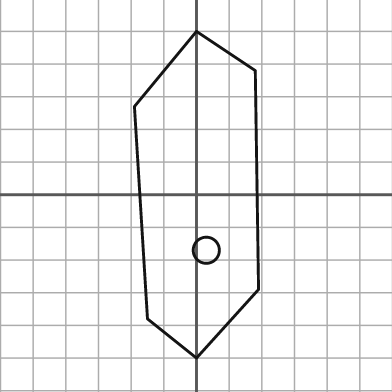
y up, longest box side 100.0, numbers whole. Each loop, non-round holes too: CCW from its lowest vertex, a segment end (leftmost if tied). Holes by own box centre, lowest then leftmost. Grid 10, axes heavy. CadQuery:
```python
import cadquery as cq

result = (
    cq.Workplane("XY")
    .moveTo(0.0, -50.0)
    .lineTo(19.0, -29.0)
    .lineTo(18.0, 38.0)
    .lineTo(0.0, 50.0)
    .lineTo(-19.0, 27.0)
    .lineTo(-15.0, -38.0)
    .close()
    .moveTo(3.0, -17.0)
    .circle(4.0)
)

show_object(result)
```